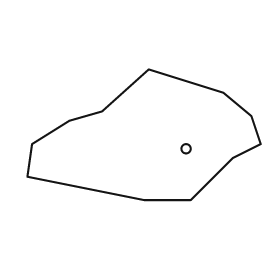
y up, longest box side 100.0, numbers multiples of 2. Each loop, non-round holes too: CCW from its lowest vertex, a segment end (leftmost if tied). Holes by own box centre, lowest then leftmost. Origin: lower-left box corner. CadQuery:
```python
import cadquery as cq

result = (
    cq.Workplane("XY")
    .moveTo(50.0, 0.0)
    .lineTo(70.0, 0.0)
    .lineTo(88.0, 18.0)
    .lineTo(100.0, 24.0)
    .lineTo(96.0, 36.0)
    .lineTo(84.0, 46.0)
    .lineTo(52.0, 56.0)
    .lineTo(32.0, 38.0)
    .lineTo(18.0, 34.0)
    .lineTo(2.0, 24.0)
    .lineTo(0.0, 10.0)
    .close()
    .moveTo(68.0, 22.0)
    .circle(2.0)
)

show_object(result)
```